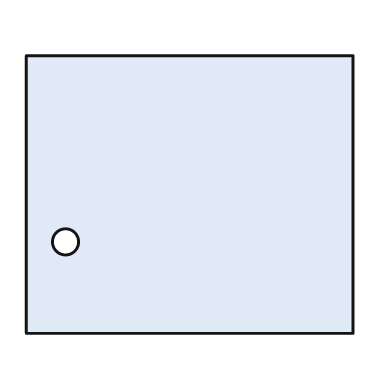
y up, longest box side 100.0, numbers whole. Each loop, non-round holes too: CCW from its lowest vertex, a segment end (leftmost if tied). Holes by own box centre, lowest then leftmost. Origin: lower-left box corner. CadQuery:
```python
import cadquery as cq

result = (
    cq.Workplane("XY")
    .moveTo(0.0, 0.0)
    .lineTo(100.0, 0.0)
    .lineTo(100.0, 85.0)
    .lineTo(0.0, 85.0)
    .close()
    .moveTo(12.0, 28.0)
    .circle(4.0)
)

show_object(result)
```